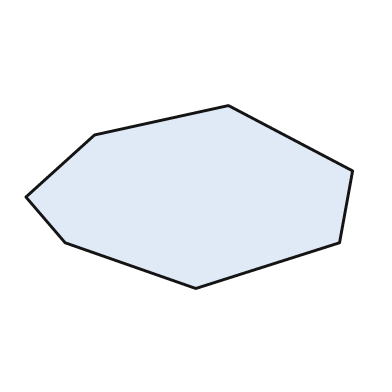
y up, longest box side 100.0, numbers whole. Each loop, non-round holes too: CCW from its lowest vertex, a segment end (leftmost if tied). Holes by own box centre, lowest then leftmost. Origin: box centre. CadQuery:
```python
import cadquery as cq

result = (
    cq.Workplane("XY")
    .moveTo(2.0, -28.0)
    .lineTo(46.0, -14.0)
    .lineTo(50.0, 8.0)
    .lineTo(12.0, 28.0)
    .lineTo(-29.0, 19.0)
    .lineTo(-50.0, 0.0)
    .lineTo(-38.0, -14.0)
    .close()
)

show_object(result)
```